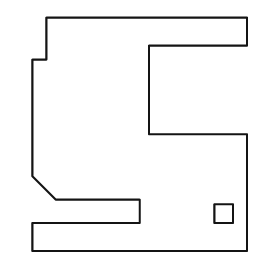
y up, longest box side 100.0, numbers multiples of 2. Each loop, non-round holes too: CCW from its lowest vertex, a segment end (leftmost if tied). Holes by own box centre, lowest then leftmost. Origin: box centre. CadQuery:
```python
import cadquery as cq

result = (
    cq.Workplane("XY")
    .moveTo(-46.0, -50.0)
    .lineTo(46.0, -50.0)
    .lineTo(46.0, 0.0)
    .lineTo(4.0, 0.0)
    .lineTo(4.0, 38.0)
    .lineTo(46.0, 38.0)
    .lineTo(46.0, 50.0)
    .lineTo(-40.0, 50.0)
    .lineTo(-40.0, 32.0)
    .lineTo(-46.0, 32.0)
    .lineTo(-46.0, -18.0)
    .lineTo(-36.0, -28.0)
    .lineTo(0.0, -28.0)
    .lineTo(0.0, -38.0)
    .lineTo(-46.0, -38.0)
    .close()
    .moveTo(32.0, -38.0)
    .lineTo(40.0, -38.0)
    .lineTo(40.0, -30.0)
    .lineTo(32.0, -30.0)
    .close()
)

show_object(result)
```